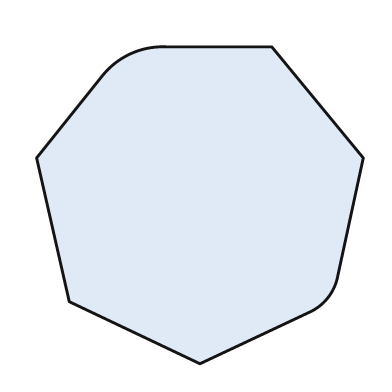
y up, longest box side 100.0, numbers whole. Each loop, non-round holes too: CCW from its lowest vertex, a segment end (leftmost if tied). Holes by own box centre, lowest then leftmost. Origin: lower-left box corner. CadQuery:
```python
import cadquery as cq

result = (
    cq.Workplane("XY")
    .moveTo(50.0, 0.0)
    .lineTo(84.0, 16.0)
    .threePointArc((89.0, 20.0), (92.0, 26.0))
    .lineTo(100.0, 63.0)
    .lineTo(72.0, 97.0)
    .lineTo(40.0, 97.0)
    .threePointArc((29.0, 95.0), (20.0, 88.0))
    .lineTo(0.0, 63.0)
    .lineTo(10.0, 19.0)
    .close()
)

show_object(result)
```